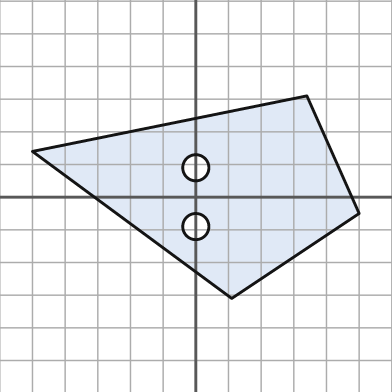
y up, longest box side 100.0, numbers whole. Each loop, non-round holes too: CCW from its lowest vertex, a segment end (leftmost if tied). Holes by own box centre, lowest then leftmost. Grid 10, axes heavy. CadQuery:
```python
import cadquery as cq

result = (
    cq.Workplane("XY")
    .moveTo(11.0, -31.0)
    .lineTo(50.0, -5.0)
    .lineTo(34.0, 31.0)
    .lineTo(-50.0, 14.0)
    .close()
    .moveTo(0.0, -9.0)
    .circle(4.0)
    .moveTo(0.0, 9.0)
    .circle(4.0)
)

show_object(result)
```